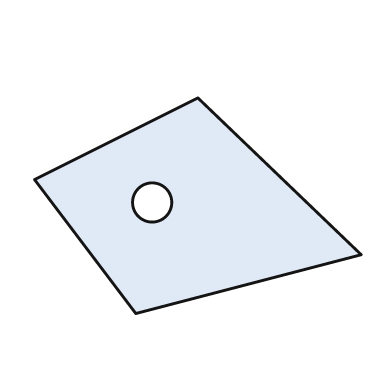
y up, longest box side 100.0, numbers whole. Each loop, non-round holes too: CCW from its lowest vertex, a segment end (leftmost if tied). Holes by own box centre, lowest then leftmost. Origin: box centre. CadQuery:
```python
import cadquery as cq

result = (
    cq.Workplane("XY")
    .moveTo(-19.0, -33.0)
    .lineTo(50.0, -15.0)
    .lineTo(0.0, 33.0)
    .lineTo(-50.0, 8.0)
    .close()
    .moveTo(-14.0, 1.0)
    .circle(6.0)
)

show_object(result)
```